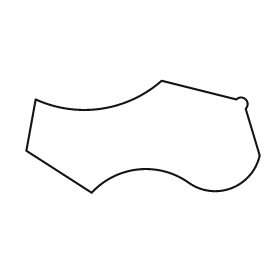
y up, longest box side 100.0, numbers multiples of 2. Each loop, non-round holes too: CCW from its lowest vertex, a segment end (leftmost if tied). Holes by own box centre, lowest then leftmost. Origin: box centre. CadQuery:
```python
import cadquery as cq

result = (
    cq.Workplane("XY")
    .moveTo(-22.0, -24.0)
    .threePointArc((-2.0, -14.0), (20.0, -20.0))
    .threePointArc((38.0, -22.0), (50.0, -8.0))
    .lineTo(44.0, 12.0)
    .threePointArc((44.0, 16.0), (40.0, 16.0))
    .lineTo(8.0, 24.0)
    .threePointArc((-18.0, 12.0), (-46.0, 16.0))
    .lineTo(-50.0, -6.0)
    .close()
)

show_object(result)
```